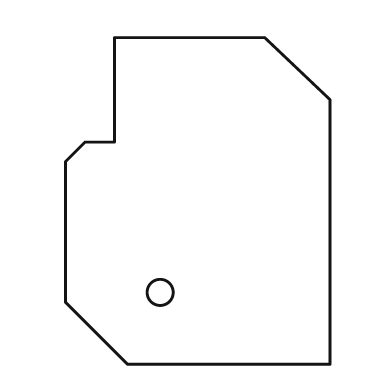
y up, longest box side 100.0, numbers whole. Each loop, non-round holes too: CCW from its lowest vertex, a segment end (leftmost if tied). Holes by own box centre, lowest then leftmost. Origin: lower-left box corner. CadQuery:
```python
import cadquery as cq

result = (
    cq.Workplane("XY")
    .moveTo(19.0, 0.0)
    .lineTo(81.0, 0.0)
    .lineTo(81.0, 81.0)
    .lineTo(61.0, 100.0)
    .lineTo(15.0, 100.0)
    .lineTo(15.0, 68.0)
    .lineTo(6.0, 68.0)
    .lineTo(0.0, 62.0)
    .lineTo(0.0, 19.0)
    .close()
    .moveTo(29.0, 22.0)
    .circle(4.0)
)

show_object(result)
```